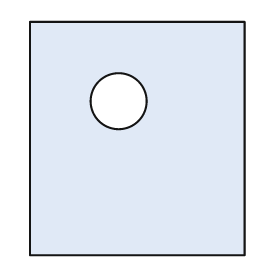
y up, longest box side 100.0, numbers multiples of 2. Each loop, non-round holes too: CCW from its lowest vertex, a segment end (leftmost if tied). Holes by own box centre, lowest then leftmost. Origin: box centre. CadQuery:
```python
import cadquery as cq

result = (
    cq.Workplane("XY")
    .moveTo(-46.0, -50.0)
    .lineTo(46.0, -50.0)
    .lineTo(46.0, 50.0)
    .lineTo(-46.0, 50.0)
    .close()
    .moveTo(-8.0, 16.0)
    .circle(12.0)
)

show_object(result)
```